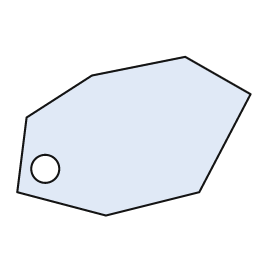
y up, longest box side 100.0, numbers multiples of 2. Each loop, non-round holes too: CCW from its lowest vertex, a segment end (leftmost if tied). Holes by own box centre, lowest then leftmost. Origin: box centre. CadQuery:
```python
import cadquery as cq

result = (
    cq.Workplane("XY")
    .moveTo(-12.0, -34.0)
    .lineTo(28.0, -24.0)
    .lineTo(50.0, 18.0)
    .lineTo(22.0, 34.0)
    .lineTo(-18.0, 26.0)
    .lineTo(-46.0, 8.0)
    .lineTo(-50.0, -24.0)
    .close()
    .moveTo(-38.0, -14.0)
    .circle(6.0)
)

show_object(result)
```